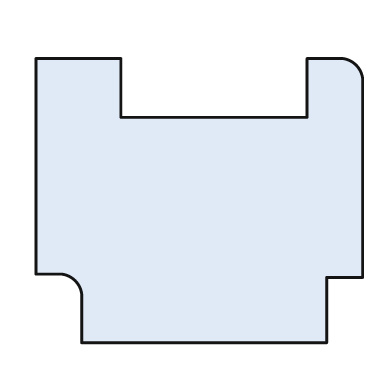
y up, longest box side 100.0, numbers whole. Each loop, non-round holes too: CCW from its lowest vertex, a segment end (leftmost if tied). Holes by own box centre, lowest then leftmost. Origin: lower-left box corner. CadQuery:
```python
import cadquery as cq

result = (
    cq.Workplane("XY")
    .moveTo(14.0, 0.0)
    .lineTo(89.0, 0.0)
    .lineTo(89.0, 20.0)
    .lineTo(100.0, 20.0)
    .lineTo(100.0, 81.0)
    .threePointArc((98.0, 85.0), (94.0, 87.0))
    .lineTo(83.0, 87.0)
    .lineTo(83.0, 69.0)
    .lineTo(26.0, 69.0)
    .lineTo(26.0, 87.0)
    .lineTo(0.0, 87.0)
    .lineTo(0.0, 21.0)
    .lineTo(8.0, 21.0)
    .threePointArc((12.0, 19.0), (14.0, 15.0))
    .close()
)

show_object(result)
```